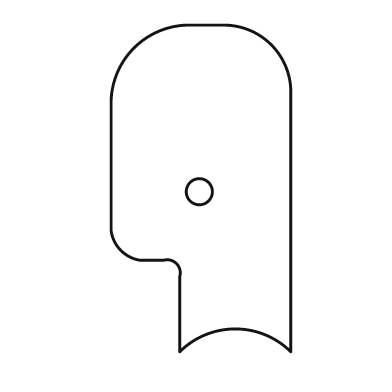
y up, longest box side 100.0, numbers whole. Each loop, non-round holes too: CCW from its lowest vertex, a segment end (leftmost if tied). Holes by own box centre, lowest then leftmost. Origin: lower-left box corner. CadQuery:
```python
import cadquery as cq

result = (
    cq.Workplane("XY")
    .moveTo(21.0, 0.0)
    .threePointArc((38.0, 7.0), (55.0, 0.0))
    .lineTo(55.0, 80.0)
    .threePointArc((49.0, 94.0), (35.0, 100.0))
    .lineTo(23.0, 100.0)
    .threePointArc((7.0, 93.0), (0.0, 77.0))
    .lineTo(0.0, 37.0)
    .threePointArc((3.0, 31.0), (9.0, 28.0))
    .lineTo(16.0, 28.0)
    .threePointArc((20.0, 27.0), (21.0, 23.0))
    .close()
    .moveTo(27.0, 49.0)
    .circle(4.0)
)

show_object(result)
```